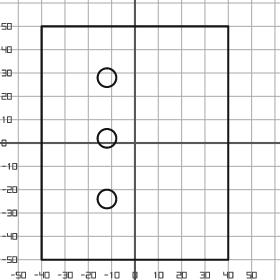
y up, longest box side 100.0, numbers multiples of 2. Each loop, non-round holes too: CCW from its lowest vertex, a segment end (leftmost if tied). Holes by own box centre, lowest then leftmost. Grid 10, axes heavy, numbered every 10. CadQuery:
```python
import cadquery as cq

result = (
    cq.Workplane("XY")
    .moveTo(-40.0, -50.0)
    .lineTo(40.0, -50.0)
    .lineTo(40.0, 50.0)
    .lineTo(-40.0, 50.0)
    .close()
    .moveTo(-12.0, -24.0)
    .circle(4.0)
    .moveTo(-12.0, 2.0)
    .circle(4.0)
    .moveTo(-12.0, 28.0)
    .circle(4.0)
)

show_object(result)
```